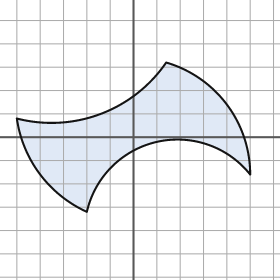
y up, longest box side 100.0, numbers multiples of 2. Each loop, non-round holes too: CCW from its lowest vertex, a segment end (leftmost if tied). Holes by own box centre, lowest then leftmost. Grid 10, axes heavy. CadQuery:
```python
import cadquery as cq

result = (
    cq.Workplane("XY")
    .moveTo(-20.0, -32.0)
    .threePointArc((10.0, -2.0), (50.0, -16.0))
    .threePointArc((40.0, 14.0), (14.0, 32.0))
    .threePointArc((-14.0, 10.0), (-50.0, 8.0))
    .threePointArc((-40.0, -16.0), (-20.0, -32.0))
    .close()
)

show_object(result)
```